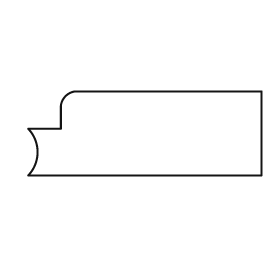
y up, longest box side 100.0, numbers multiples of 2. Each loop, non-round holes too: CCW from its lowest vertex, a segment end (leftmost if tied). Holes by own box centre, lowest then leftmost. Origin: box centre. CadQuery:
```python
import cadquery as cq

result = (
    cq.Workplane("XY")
    .moveTo(-50.0, -18.0)
    .lineTo(50.0, -18.0)
    .lineTo(50.0, 18.0)
    .lineTo(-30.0, 18.0)
    .threePointArc((-34.0, 16.0), (-36.0, 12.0))
    .lineTo(-36.0, 2.0)
    .lineTo(-50.0, 2.0)
    .threePointArc((-46.0, -8.0), (-50.0, -18.0))
    .close()
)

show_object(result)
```